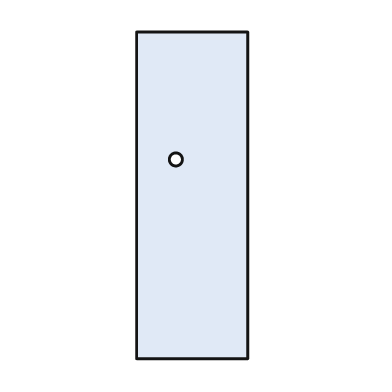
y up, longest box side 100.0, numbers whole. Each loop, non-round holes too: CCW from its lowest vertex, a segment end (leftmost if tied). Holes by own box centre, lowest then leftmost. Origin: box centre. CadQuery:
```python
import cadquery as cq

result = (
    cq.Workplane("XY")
    .moveTo(-17.0, -50.0)
    .lineTo(17.0, -50.0)
    .lineTo(17.0, 50.0)
    .lineTo(-17.0, 50.0)
    .close()
    .moveTo(-5.0, 11.0)
    .circle(2.0)
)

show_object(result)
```